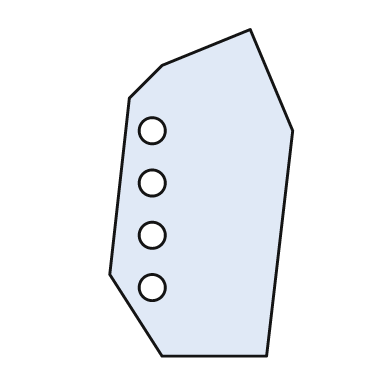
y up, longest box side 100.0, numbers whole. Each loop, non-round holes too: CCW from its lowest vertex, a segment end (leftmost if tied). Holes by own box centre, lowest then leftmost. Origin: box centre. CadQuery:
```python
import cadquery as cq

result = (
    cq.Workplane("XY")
    .moveTo(-12.0, -50.0)
    .lineTo(20.0, -50.0)
    .lineTo(28.0, 19.0)
    .lineTo(15.0, 50.0)
    .lineTo(-12.0, 39.0)
    .lineTo(-22.0, 29.0)
    .lineTo(-28.0, -25.0)
    .close()
    .moveTo(-15.0, -29.0)
    .circle(4.0)
    .moveTo(-15.0, -13.0)
    .circle(4.0)
    .moveTo(-15.0, 3.0)
    .circle(4.0)
    .moveTo(-15.0, 19.0)
    .circle(4.0)
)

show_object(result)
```